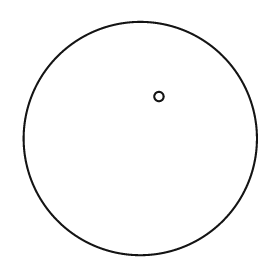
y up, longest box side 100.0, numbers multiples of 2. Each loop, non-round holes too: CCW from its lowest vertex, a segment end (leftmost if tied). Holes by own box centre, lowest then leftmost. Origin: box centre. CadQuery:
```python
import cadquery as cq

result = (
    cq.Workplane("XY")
    .moveTo(0.0, 0.0)
    .circle(50.0)
    .moveTo(8.0, 18.0)
    .circle(2.0)
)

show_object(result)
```